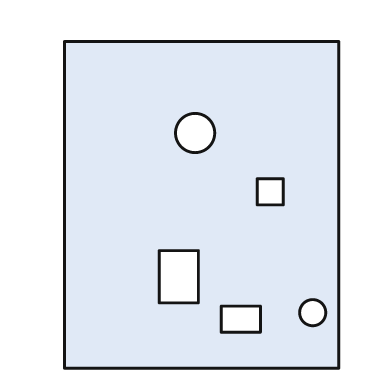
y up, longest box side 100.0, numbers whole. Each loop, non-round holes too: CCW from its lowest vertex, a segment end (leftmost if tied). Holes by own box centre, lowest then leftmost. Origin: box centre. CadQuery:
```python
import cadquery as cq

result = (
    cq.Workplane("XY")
    .moveTo(-42.0, -50.0)
    .lineTo(42.0, -50.0)
    .lineTo(42.0, 50.0)
    .lineTo(-42.0, 50.0)
    .close()
    .moveTo(6.0, -39.0)
    .lineTo(18.0, -39.0)
    .lineTo(18.0, -31.0)
    .lineTo(6.0, -31.0)
    .close()
    .moveTo(34.0, -33.0)
    .circle(4.0)
    .moveTo(-13.0, -30.0)
    .lineTo(-1.0, -30.0)
    .lineTo(-1.0, -14.0)
    .lineTo(-13.0, -14.0)
    .close()
    .moveTo(17.0, 0.0)
    .lineTo(25.0, 0.0)
    .lineTo(25.0, 8.0)
    .lineTo(17.0, 8.0)
    .close()
    .moveTo(-2.0, 22.0)
    .circle(6.0)
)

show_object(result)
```